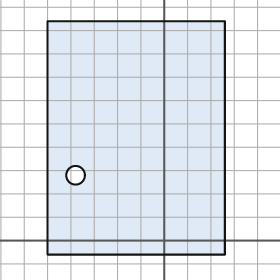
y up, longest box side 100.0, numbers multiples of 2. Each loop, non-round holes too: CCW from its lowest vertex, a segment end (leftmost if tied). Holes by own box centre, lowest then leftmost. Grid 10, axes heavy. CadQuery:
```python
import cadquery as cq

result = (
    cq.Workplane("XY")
    .moveTo(-50.0, -6.0)
    .lineTo(26.0, -6.0)
    .lineTo(26.0, 94.0)
    .lineTo(-50.0, 94.0)
    .close()
    .moveTo(-38.0, 28.0)
    .circle(4.0)
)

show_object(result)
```